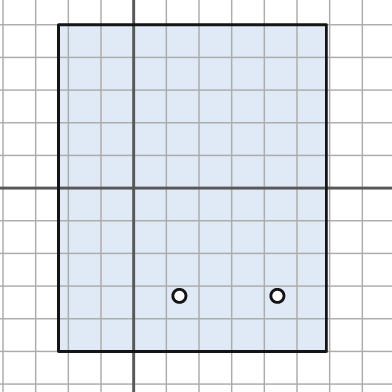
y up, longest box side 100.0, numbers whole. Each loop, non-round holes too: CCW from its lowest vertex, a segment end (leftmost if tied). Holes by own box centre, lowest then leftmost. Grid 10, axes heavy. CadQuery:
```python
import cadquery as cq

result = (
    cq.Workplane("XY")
    .moveTo(-23.0, -50.0)
    .lineTo(59.0, -50.0)
    .lineTo(59.0, 50.0)
    .lineTo(-23.0, 50.0)
    .close()
    .moveTo(14.0, -33.0)
    .circle(2.0)
    .moveTo(44.0, -33.0)
    .circle(2.0)
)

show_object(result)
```